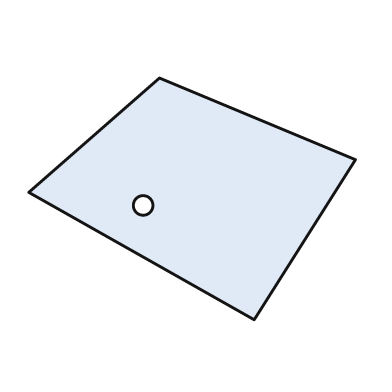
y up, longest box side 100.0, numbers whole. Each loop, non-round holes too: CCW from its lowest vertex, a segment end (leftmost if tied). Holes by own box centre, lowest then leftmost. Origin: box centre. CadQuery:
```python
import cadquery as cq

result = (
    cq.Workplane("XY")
    .moveTo(19.0, -37.0)
    .lineTo(50.0, 12.0)
    .lineTo(-10.0, 37.0)
    .lineTo(-50.0, 2.0)
    .close()
    .moveTo(-15.0, -2.0)
    .circle(3.0)
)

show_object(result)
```